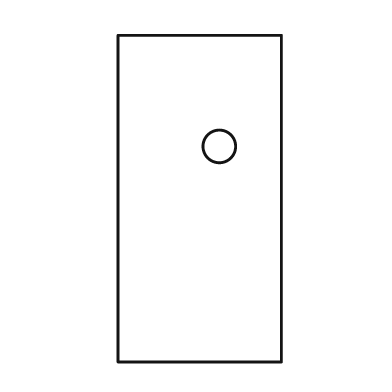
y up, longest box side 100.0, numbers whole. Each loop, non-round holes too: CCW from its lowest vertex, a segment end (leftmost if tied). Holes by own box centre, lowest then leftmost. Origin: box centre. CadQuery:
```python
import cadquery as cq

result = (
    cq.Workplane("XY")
    .moveTo(-25.0, -50.0)
    .lineTo(25.0, -50.0)
    .lineTo(25.0, 50.0)
    .lineTo(-25.0, 50.0)
    .close()
    .moveTo(6.0, 16.0)
    .circle(5.0)
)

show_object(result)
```